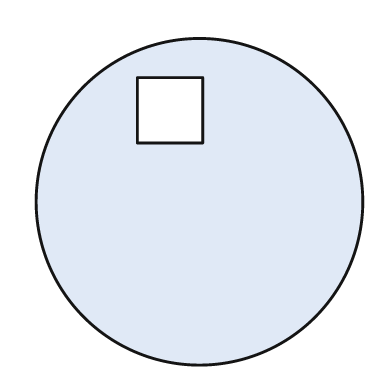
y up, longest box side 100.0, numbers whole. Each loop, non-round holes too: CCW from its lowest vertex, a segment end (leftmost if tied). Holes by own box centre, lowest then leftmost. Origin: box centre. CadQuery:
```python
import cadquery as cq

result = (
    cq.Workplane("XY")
    .moveTo(0.0, 0.0)
    .circle(50.0)
    .moveTo(-19.0, 18.0)
    .lineTo(1.0, 18.0)
    .lineTo(1.0, 38.0)
    .lineTo(-19.0, 38.0)
    .close()
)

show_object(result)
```